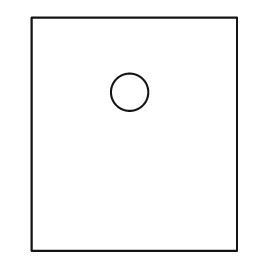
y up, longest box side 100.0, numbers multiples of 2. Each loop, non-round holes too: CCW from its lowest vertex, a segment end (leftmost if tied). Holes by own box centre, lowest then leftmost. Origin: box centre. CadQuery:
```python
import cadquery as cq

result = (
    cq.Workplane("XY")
    .moveTo(-44.0, -50.0)
    .lineTo(44.0, -50.0)
    .lineTo(44.0, 50.0)
    .lineTo(-44.0, 50.0)
    .close()
    .moveTo(-2.0, 18.0)
    .circle(8.0)
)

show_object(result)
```